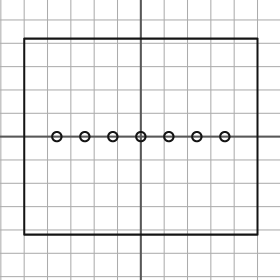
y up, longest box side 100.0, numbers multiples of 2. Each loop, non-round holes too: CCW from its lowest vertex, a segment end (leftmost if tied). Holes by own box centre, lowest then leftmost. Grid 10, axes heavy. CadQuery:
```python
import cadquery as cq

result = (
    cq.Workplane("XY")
    .moveTo(-50.0, -42.0)
    .lineTo(50.0, -42.0)
    .lineTo(50.0, 42.0)
    .lineTo(-50.0, 42.0)
    .close()
    .moveTo(-36.0, 0.0)
    .circle(2.0)
    .moveTo(-24.0, 0.0)
    .circle(2.0)
    .moveTo(-12.0, 0.0)
    .circle(2.0)
    .moveTo(0.0, 0.0)
    .circle(2.0)
    .moveTo(12.0, 0.0)
    .circle(2.0)
    .moveTo(24.0, 0.0)
    .circle(2.0)
    .moveTo(36.0, 0.0)
    .circle(2.0)
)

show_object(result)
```